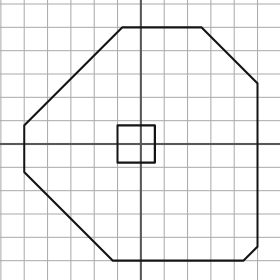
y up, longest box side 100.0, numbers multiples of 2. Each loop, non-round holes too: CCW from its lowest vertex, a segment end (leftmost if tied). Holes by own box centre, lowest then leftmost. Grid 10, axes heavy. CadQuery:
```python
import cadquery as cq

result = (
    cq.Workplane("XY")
    .moveTo(-12.0, -50.0)
    .lineTo(44.0, -50.0)
    .lineTo(50.0, -44.0)
    .lineTo(50.0, 26.0)
    .lineTo(26.0, 50.0)
    .lineTo(-8.0, 50.0)
    .lineTo(-50.0, 8.0)
    .lineTo(-50.0, -12.0)
    .close()
    .moveTo(-10.0, -8.0)
    .lineTo(6.0, -8.0)
    .lineTo(6.0, 8.0)
    .lineTo(-10.0, 8.0)
    .close()
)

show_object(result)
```